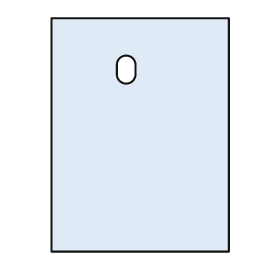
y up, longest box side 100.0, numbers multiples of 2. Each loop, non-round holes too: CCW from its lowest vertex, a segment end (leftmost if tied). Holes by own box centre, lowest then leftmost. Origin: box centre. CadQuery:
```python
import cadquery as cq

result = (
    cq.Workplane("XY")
    .moveTo(-38.0, -50.0)
    .lineTo(38.0, -50.0)
    .lineTo(38.0, 50.0)
    .lineTo(-38.0, 50.0)
    .close()
    .moveTo(-10.0, 26.0)
    .threePointArc((-6.0, 22.0), (-2.0, 26.0))
    .lineTo(-2.0, 30.0)
    .threePointArc((-6.0, 34.0), (-10.0, 30.0))
    .close()
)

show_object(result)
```